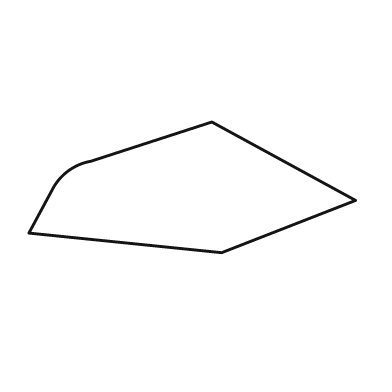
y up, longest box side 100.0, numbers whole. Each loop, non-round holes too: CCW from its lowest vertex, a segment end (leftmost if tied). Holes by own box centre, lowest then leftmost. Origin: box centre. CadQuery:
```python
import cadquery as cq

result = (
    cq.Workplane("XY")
    .moveTo(9.0, -20.0)
    .lineTo(50.0, -4.0)
    .lineTo(6.0, 20.0)
    .lineTo(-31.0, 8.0)
    .threePointArc((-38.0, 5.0), (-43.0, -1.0))
    .lineTo(-50.0, -14.0)
    .close()
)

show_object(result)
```